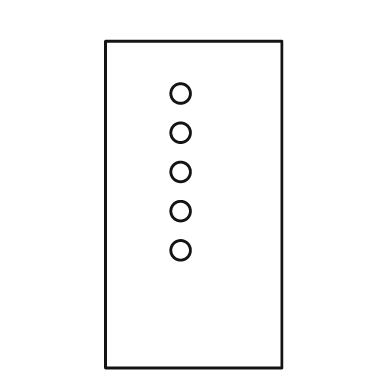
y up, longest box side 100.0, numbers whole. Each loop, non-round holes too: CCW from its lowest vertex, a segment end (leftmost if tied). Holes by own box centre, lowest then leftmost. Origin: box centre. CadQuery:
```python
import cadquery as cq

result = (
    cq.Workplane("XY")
    .moveTo(-27.0, -50.0)
    .lineTo(27.0, -50.0)
    .lineTo(27.0, 50.0)
    .lineTo(-27.0, 50.0)
    .close()
    .moveTo(-4.0, -14.0)
    .circle(3.0)
    .moveTo(-4.0, -2.0)
    .circle(3.0)
    .moveTo(-4.0, 10.0)
    .circle(3.0)
    .moveTo(-4.0, 22.0)
    .circle(3.0)
    .moveTo(-4.0, 34.0)
    .circle(3.0)
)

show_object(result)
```